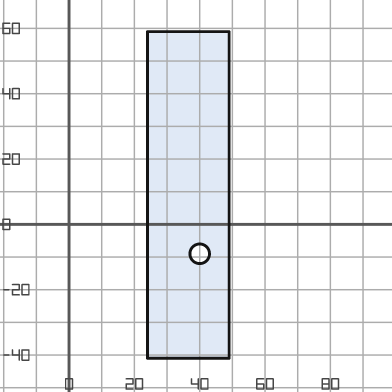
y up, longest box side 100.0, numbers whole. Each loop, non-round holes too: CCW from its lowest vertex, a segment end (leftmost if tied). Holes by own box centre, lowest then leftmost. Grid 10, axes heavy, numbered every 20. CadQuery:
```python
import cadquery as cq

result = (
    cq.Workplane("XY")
    .moveTo(24.0, -41.0)
    .lineTo(49.0, -41.0)
    .lineTo(49.0, 59.0)
    .lineTo(24.0, 59.0)
    .close()
    .moveTo(40.0, -9.0)
    .circle(3.0)
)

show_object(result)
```